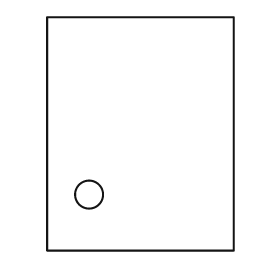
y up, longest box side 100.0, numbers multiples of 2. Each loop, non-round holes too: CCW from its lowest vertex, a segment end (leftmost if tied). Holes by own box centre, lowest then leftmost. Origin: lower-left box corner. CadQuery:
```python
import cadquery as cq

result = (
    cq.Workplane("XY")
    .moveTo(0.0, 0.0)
    .lineTo(80.0, 0.0)
    .lineTo(80.0, 100.0)
    .lineTo(0.0, 100.0)
    .close()
    .moveTo(18.0, 24.0)
    .circle(6.0)
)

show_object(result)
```